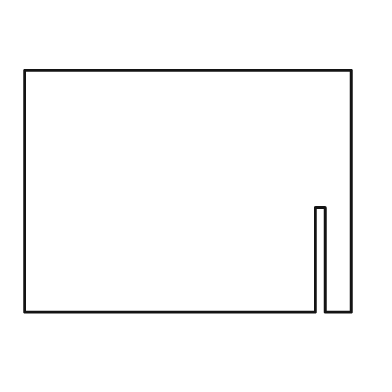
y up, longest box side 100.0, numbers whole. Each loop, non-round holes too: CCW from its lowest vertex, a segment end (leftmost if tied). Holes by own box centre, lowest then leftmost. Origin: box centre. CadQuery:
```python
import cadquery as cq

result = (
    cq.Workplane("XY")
    .moveTo(-50.0, -37.0)
    .lineTo(39.0, -37.0)
    .lineTo(39.0, -5.0)
    .lineTo(42.0, -5.0)
    .lineTo(42.0, -37.0)
    .lineTo(50.0, -37.0)
    .lineTo(50.0, 37.0)
    .lineTo(-50.0, 37.0)
    .close()
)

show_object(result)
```